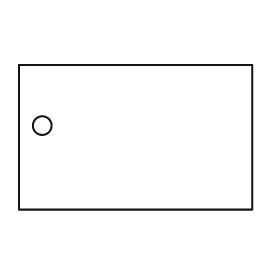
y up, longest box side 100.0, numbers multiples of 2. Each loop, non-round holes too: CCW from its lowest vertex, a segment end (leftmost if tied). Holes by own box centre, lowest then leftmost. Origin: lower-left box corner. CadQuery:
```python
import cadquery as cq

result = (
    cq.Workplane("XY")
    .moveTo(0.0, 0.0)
    .lineTo(100.0, 0.0)
    .lineTo(100.0, 62.0)
    .lineTo(0.0, 62.0)
    .close()
    .moveTo(10.0, 36.0)
    .circle(4.0)
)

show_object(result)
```